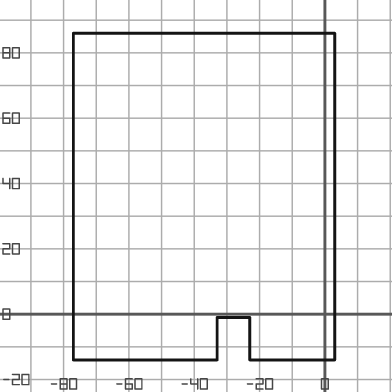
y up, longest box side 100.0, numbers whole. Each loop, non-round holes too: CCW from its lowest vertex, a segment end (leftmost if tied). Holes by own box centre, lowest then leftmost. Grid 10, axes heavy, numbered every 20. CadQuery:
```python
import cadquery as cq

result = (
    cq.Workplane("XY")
    .moveTo(-77.0, -14.0)
    .lineTo(-33.0, -14.0)
    .lineTo(-33.0, -1.0)
    .lineTo(-23.0, -1.0)
    .lineTo(-23.0, -14.0)
    .lineTo(3.0, -14.0)
    .lineTo(3.0, 86.0)
    .lineTo(-77.0, 86.0)
    .close()
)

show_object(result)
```